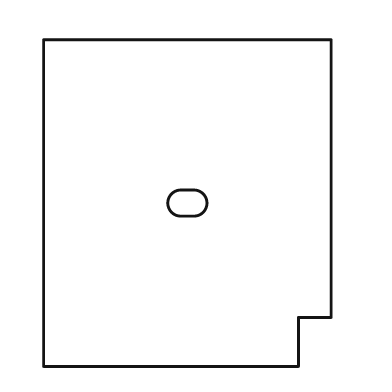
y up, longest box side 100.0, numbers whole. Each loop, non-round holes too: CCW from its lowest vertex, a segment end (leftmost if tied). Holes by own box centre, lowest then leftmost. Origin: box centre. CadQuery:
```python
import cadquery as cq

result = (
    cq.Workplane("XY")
    .moveTo(-44.0, -50.0)
    .lineTo(34.0, -50.0)
    .lineTo(34.0, -35.0)
    .lineTo(44.0, -35.0)
    .lineTo(44.0, 50.0)
    .lineTo(-44.0, 50.0)
    .close()
    .moveTo(-2.0, -4.0)
    .lineTo(2.0, -4.0)
    .threePointArc((6.0, 0.0), (2.0, 4.0))
    .lineTo(-2.0, 4.0)
    .threePointArc((-6.0, 0.0), (-2.0, -4.0))
    .close()
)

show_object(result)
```